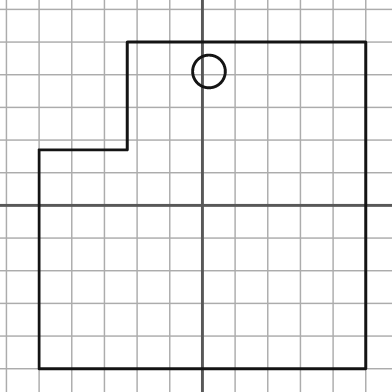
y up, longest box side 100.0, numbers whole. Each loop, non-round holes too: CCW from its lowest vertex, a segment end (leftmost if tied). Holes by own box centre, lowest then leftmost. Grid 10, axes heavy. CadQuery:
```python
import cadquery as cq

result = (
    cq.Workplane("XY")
    .moveTo(-50.0, -50.0)
    .lineTo(50.0, -50.0)
    .lineTo(50.0, 50.0)
    .lineTo(-23.0, 50.0)
    .lineTo(-23.0, 17.0)
    .lineTo(-50.0, 17.0)
    .close()
    .moveTo(2.0, 41.0)
    .circle(5.0)
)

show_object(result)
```